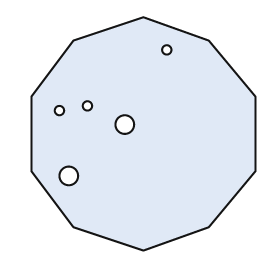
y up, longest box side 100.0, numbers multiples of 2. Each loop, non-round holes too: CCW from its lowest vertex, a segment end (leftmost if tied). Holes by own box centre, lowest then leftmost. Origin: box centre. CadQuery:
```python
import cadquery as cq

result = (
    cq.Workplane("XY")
    .moveTo(0.0, -50.0)
    .lineTo(28.0, -40.0)
    .lineTo(48.0, -16.0)
    .lineTo(48.0, 16.0)
    .lineTo(28.0, 40.0)
    .lineTo(0.0, 50.0)
    .lineTo(-30.0, 40.0)
    .lineTo(-48.0, 16.0)
    .lineTo(-48.0, -16.0)
    .lineTo(-30.0, -40.0)
    .close()
    .moveTo(-32.0, -18.0)
    .circle(4.0)
    .moveTo(-8.0, 4.0)
    .circle(4.0)
    .moveTo(-36.0, 10.0)
    .circle(2.0)
    .moveTo(-24.0, 12.0)
    .circle(2.0)
    .moveTo(10.0, 36.0)
    .circle(2.0)
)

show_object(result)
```